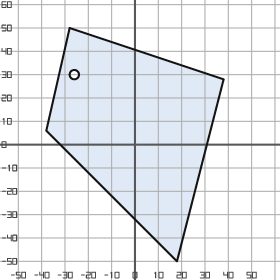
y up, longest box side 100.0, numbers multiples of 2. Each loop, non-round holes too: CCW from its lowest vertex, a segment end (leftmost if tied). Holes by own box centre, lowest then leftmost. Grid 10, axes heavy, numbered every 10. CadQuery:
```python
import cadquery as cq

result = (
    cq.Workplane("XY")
    .moveTo(18.0, -50.0)
    .lineTo(38.0, 28.0)
    .lineTo(-28.0, 50.0)
    .lineTo(-38.0, 6.0)
    .close()
    .moveTo(-26.0, 30.0)
    .circle(2.0)
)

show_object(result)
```